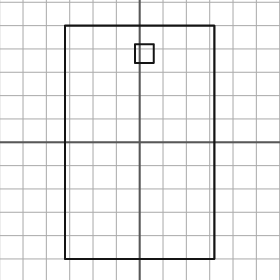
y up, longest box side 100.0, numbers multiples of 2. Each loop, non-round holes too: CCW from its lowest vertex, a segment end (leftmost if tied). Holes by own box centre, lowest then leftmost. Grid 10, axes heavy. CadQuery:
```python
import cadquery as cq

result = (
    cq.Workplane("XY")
    .moveTo(-32.0, -50.0)
    .lineTo(32.0, -50.0)
    .lineTo(32.0, 50.0)
    .lineTo(-32.0, 50.0)
    .close()
    .moveTo(-2.0, 34.0)
    .lineTo(6.0, 34.0)
    .lineTo(6.0, 42.0)
    .lineTo(-2.0, 42.0)
    .close()
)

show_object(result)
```